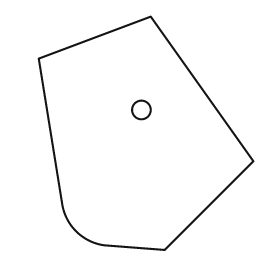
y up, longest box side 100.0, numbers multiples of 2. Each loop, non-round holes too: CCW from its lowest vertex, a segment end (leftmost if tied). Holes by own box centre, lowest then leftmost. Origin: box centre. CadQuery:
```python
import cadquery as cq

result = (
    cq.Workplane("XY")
    .moveTo(8.0, -50.0)
    .lineTo(46.0, -12.0)
    .lineTo(2.0, 50.0)
    .lineTo(-46.0, 32.0)
    .lineTo(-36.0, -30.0)
    .threePointArc((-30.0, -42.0), (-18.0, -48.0))
    .close()
    .moveTo(-2.0, 10.0)
    .circle(4.0)
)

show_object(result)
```